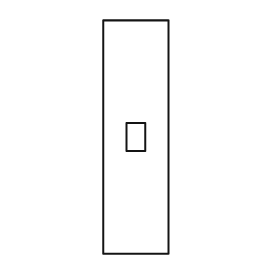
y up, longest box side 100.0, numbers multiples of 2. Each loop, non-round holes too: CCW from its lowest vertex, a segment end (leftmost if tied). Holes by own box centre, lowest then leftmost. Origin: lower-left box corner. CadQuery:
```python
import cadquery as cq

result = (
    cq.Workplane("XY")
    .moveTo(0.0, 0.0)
    .lineTo(28.0, 0.0)
    .lineTo(28.0, 100.0)
    .lineTo(0.0, 100.0)
    .close()
    .moveTo(10.0, 44.0)
    .lineTo(18.0, 44.0)
    .lineTo(18.0, 56.0)
    .lineTo(10.0, 56.0)
    .close()
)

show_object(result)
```